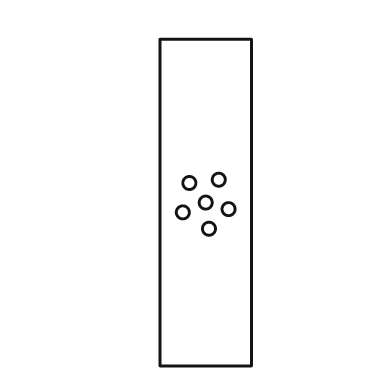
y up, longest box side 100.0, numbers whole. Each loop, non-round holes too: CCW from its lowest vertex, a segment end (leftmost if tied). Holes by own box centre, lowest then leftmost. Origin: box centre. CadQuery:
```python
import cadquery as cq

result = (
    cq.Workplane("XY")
    .moveTo(-14.0, -50.0)
    .lineTo(14.0, -50.0)
    .lineTo(14.0, 50.0)
    .lineTo(-14.0, 50.0)
    .close()
    .moveTo(1.0, -8.0)
    .circle(2.0)
    .moveTo(-7.0, -3.0)
    .circle(2.0)
    .moveTo(7.0, -2.0)
    .circle(2.0)
    .moveTo(0.0, 0.0)
    .circle(2.0)
    .moveTo(-5.0, 6.0)
    .circle(2.0)
    .moveTo(4.0, 7.0)
    .circle(2.0)
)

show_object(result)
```